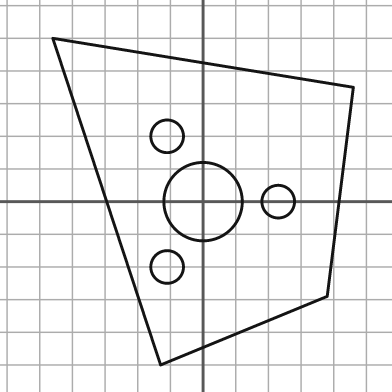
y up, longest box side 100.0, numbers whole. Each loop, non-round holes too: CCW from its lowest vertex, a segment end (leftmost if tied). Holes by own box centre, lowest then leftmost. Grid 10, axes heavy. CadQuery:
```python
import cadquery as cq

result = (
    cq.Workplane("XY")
    .moveTo(-13.0, -50.0)
    .lineTo(38.0, -29.0)
    .lineTo(46.0, 35.0)
    .lineTo(-46.0, 50.0)
    .close()
    .moveTo(-11.0, -20.0)
    .circle(5.0)
    .moveTo(0.0, 0.0)
    .circle(12.0)
    .moveTo(23.0, 0.0)
    .circle(5.0)
    .moveTo(-11.0, 20.0)
    .circle(5.0)
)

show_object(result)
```